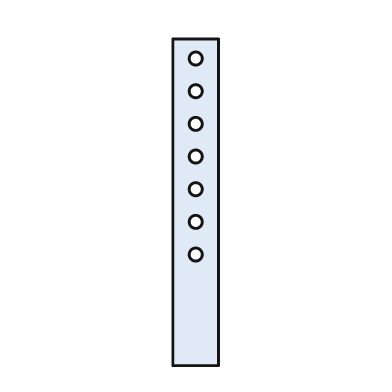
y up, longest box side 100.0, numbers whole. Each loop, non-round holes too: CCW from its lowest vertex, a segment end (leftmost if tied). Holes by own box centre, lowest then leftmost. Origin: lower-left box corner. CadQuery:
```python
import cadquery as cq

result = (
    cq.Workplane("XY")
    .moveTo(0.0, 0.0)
    .lineTo(14.0, 0.0)
    .lineTo(14.0, 100.0)
    .lineTo(0.0, 100.0)
    .close()
    .moveTo(7.0, 34.0)
    .circle(2.0)
    .moveTo(7.0, 44.0)
    .circle(2.0)
    .moveTo(7.0, 54.0)
    .circle(2.0)
    .moveTo(7.0, 64.0)
    .circle(2.0)
    .moveTo(7.0, 74.0)
    .circle(2.0)
    .moveTo(7.0, 84.0)
    .circle(2.0)
    .moveTo(7.0, 94.0)
    .circle(2.0)
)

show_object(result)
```